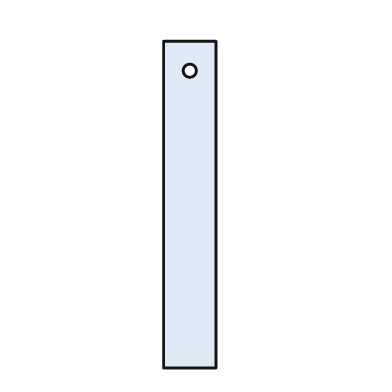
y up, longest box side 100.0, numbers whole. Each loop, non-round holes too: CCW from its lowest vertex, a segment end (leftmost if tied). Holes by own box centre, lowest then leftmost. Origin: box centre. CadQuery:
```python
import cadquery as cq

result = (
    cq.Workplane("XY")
    .moveTo(-8.0, -50.0)
    .lineTo(8.0, -50.0)
    .lineTo(8.0, 50.0)
    .lineTo(-8.0, 50.0)
    .close()
    .moveTo(0.0, 41.0)
    .circle(2.0)
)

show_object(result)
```